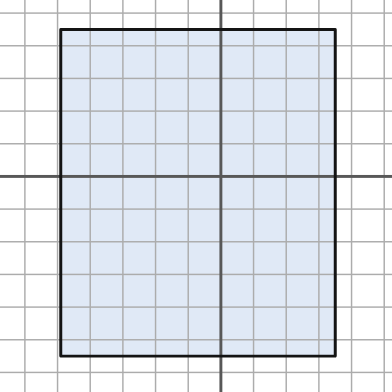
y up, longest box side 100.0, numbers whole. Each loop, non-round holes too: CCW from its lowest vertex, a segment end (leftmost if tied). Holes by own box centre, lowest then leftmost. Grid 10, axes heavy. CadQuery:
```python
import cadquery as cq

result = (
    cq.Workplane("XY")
    .moveTo(-49.0, -55.0)
    .lineTo(35.0, -55.0)
    .lineTo(35.0, 45.0)
    .lineTo(-49.0, 45.0)
    .close()
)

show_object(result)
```